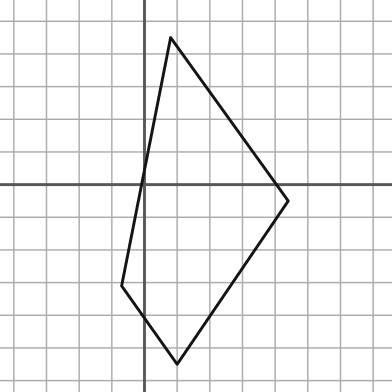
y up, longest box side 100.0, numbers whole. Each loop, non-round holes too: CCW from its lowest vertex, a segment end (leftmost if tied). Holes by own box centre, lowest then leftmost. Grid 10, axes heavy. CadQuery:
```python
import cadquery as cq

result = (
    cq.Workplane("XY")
    .moveTo(10.0, -55.0)
    .lineTo(44.0, -5.0)
    .lineTo(8.0, 45.0)
    .lineTo(-7.0, -31.0)
    .close()
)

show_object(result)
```